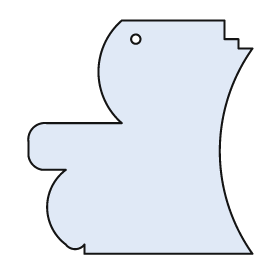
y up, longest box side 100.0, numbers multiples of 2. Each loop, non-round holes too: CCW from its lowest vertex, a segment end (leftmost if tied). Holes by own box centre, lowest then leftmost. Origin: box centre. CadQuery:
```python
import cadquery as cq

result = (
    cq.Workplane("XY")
    .moveTo(-24.0, -50.0)
    .lineTo(48.0, -50.0)
    .threePointArc((34.0, -6.0), (48.0, 38.0))
    .lineTo(42.0, 38.0)
    .lineTo(42.0, 42.0)
    .lineTo(36.0, 42.0)
    .lineTo(36.0, 50.0)
    .lineTo(-8.0, 50.0)
    .threePointArc((-18.0, 28.0), (-8.0, 6.0))
    .lineTo(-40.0, 6.0)
    .threePointArc((-46.0, 4.0), (-48.0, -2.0))
    .lineTo(-48.0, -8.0)
    .threePointArc((-46.0, -12.0), (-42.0, -14.0))
    .lineTo(-32.0, -14.0)
    .threePointArc((-40.0, -30.0), (-32.0, -46.0))
    .threePointArc((-28.0, -48.0), (-24.0, -46.0))
    .close()
    .moveTo(-2.0, 42.0)
    .circle(2.0)
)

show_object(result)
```